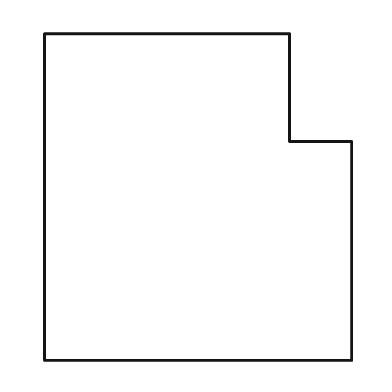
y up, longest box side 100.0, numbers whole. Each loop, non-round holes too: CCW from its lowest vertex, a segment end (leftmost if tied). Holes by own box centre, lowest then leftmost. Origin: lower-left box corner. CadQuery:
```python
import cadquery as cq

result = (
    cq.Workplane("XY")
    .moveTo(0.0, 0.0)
    .lineTo(94.0, 0.0)
    .lineTo(94.0, 67.0)
    .lineTo(75.0, 67.0)
    .lineTo(75.0, 100.0)
    .lineTo(0.0, 100.0)
    .close()
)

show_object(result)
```